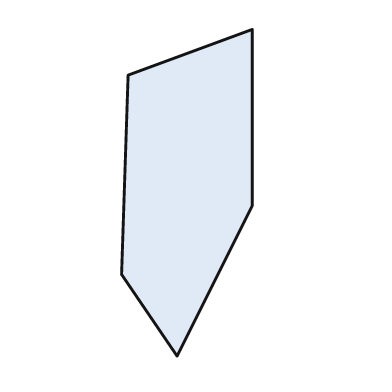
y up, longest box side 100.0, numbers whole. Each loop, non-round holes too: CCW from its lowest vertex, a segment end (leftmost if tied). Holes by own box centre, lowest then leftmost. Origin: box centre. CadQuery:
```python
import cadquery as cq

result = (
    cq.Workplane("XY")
    .moveTo(-3.0, -50.0)
    .lineTo(20.0, -4.0)
    .lineTo(20.0, 50.0)
    .lineTo(-18.0, 36.0)
    .lineTo(-20.0, -25.0)
    .close()
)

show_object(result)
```